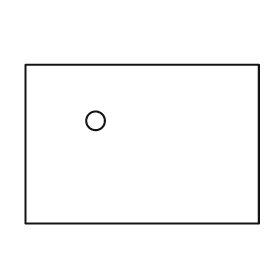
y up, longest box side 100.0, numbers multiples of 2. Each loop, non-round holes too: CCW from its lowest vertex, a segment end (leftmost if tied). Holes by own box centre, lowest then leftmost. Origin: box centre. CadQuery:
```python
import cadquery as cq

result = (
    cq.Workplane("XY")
    .moveTo(-50.0, -34.0)
    .lineTo(50.0, -34.0)
    .lineTo(50.0, 34.0)
    .lineTo(-50.0, 34.0)
    .close()
    .moveTo(-20.0, 10.0)
    .circle(4.0)
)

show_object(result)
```